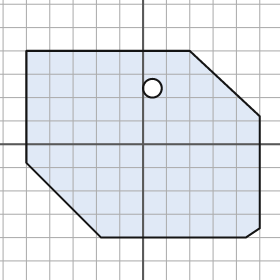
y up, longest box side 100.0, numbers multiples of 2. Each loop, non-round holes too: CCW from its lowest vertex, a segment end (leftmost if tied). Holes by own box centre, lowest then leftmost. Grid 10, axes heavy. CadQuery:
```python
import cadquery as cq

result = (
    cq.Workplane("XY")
    .moveTo(-18.0, -40.0)
    .lineTo(44.0, -40.0)
    .lineTo(50.0, -36.0)
    .lineTo(50.0, 12.0)
    .lineTo(20.0, 40.0)
    .lineTo(-50.0, 40.0)
    .lineTo(-50.0, -8.0)
    .close()
    .moveTo(4.0, 24.0)
    .circle(4.0)
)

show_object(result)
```